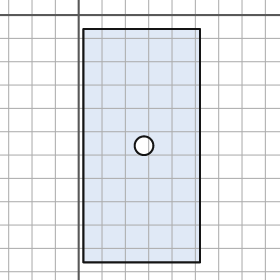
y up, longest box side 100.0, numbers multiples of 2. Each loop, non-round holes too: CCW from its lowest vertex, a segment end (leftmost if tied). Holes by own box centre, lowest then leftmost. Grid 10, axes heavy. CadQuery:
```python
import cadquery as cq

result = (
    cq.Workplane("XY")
    .moveTo(2.0, -106.0)
    .lineTo(52.0, -106.0)
    .lineTo(52.0, -6.0)
    .lineTo(2.0, -6.0)
    .close()
    .moveTo(28.0, -56.0)
    .circle(4.0)
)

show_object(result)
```